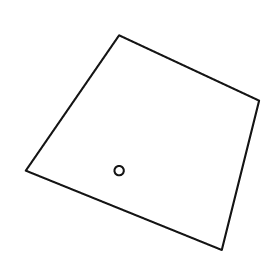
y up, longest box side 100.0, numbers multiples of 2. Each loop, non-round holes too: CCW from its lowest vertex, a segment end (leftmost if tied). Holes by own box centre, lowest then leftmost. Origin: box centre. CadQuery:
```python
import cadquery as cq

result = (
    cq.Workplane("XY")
    .moveTo(34.0, -46.0)
    .lineTo(50.0, 18.0)
    .lineTo(-10.0, 46.0)
    .lineTo(-50.0, -12.0)
    .close()
    .moveTo(-10.0, -12.0)
    .circle(2.0)
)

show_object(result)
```